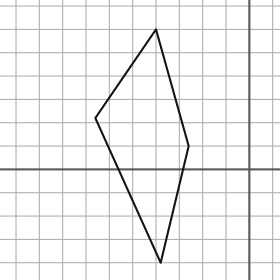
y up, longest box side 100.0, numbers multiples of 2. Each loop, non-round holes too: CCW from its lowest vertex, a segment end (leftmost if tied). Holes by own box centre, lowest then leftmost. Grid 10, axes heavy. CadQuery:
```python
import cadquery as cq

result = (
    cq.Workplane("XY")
    .moveTo(-38.0, -40.0)
    .lineTo(-26.0, 10.0)
    .lineTo(-40.0, 60.0)
    .lineTo(-66.0, 22.0)
    .close()
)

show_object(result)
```